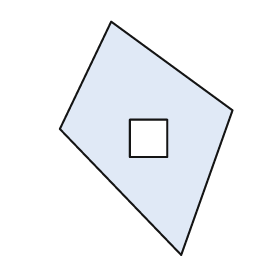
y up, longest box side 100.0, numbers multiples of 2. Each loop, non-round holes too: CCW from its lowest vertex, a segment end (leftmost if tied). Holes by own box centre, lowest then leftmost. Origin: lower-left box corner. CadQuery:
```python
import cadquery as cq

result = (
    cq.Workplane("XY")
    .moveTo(52.0, 0.0)
    .lineTo(74.0, 62.0)
    .lineTo(22.0, 100.0)
    .lineTo(0.0, 54.0)
    .close()
    .moveTo(30.0, 42.0)
    .lineTo(46.0, 42.0)
    .lineTo(46.0, 58.0)
    .lineTo(30.0, 58.0)
    .close()
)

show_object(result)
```